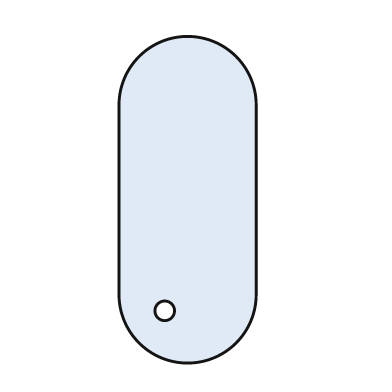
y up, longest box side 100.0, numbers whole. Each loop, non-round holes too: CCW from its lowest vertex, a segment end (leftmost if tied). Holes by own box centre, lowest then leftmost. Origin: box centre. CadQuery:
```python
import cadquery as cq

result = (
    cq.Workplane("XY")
    .moveTo(-21.0, -29.0)
    .threePointArc((0.0, -50.0), (21.0, -29.0))
    .lineTo(21.0, 29.0)
    .threePointArc((0.0, 50.0), (-21.0, 29.0))
    .close()
    .moveTo(-7.0, -34.0)
    .circle(3.0)
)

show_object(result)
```